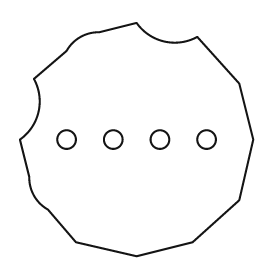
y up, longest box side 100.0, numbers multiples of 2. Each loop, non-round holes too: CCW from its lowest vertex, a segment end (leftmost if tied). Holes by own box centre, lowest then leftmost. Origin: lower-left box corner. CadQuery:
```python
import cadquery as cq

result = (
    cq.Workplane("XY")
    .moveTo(50.0, 0.0)
    .lineTo(74.0, 6.0)
    .lineTo(94.0, 24.0)
    .lineTo(100.0, 50.0)
    .lineTo(94.0, 74.0)
    .lineTo(76.0, 94.0)
    .threePointArc((62.0, 92.0), (50.0, 100.0))
    .lineTo(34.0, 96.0)
    .threePointArc((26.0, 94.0), (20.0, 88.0))
    .lineTo(6.0, 76.0)
    .threePointArc((8.0, 62.0), (0.0, 50.0))
    .lineTo(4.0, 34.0)
    .threePointArc((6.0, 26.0), (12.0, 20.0))
    .lineTo(24.0, 6.0)
    .close()
    .moveTo(20.0, 50.0)
    .circle(4.0)
    .moveTo(40.0, 50.0)
    .circle(4.0)
    .moveTo(60.0, 50.0)
    .circle(4.0)
    .moveTo(80.0, 50.0)
    .circle(4.0)
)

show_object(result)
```